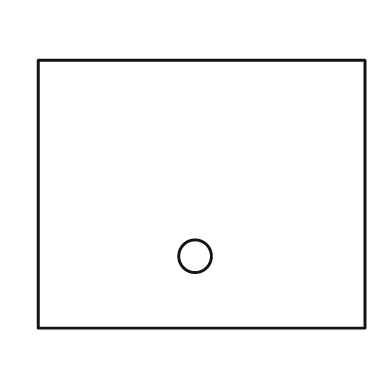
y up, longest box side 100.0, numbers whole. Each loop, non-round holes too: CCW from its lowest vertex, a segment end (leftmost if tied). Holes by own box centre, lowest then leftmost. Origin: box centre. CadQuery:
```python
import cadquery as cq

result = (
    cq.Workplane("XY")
    .moveTo(-50.0, -41.0)
    .lineTo(50.0, -41.0)
    .lineTo(50.0, 41.0)
    .lineTo(-50.0, 41.0)
    .close()
    .moveTo(-2.0, -19.0)
    .circle(5.0)
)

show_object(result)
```